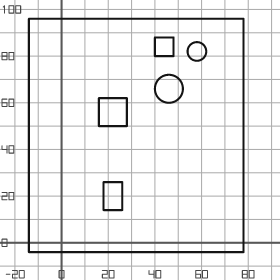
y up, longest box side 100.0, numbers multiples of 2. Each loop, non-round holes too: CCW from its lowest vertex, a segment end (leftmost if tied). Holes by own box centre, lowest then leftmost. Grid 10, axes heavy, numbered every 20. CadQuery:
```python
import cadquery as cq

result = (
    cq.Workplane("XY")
    .moveTo(-14.0, -4.0)
    .lineTo(78.0, -4.0)
    .lineTo(78.0, 96.0)
    .lineTo(-14.0, 96.0)
    .close()
    .moveTo(18.0, 14.0)
    .lineTo(26.0, 14.0)
    .lineTo(26.0, 26.0)
    .lineTo(18.0, 26.0)
    .close()
    .moveTo(16.0, 50.0)
    .lineTo(28.0, 50.0)
    .lineTo(28.0, 62.0)
    .lineTo(16.0, 62.0)
    .close()
    .moveTo(46.0, 66.0)
    .circle(6.0)
    .moveTo(58.0, 82.0)
    .circle(4.0)
    .moveTo(40.0, 80.0)
    .lineTo(48.0, 80.0)
    .lineTo(48.0, 88.0)
    .lineTo(40.0, 88.0)
    .close()
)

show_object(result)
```